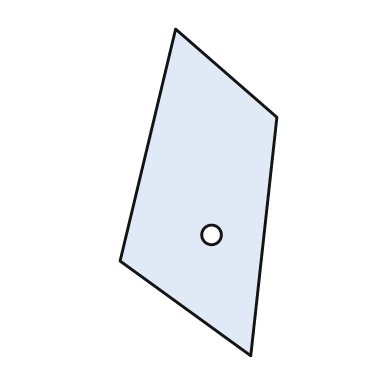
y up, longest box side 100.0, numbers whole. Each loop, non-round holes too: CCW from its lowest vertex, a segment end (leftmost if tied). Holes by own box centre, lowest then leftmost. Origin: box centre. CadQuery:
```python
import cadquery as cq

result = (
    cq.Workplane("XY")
    .moveTo(16.0, -50.0)
    .lineTo(24.0, 23.0)
    .lineTo(-7.0, 50.0)
    .lineTo(-24.0, -21.0)
    .close()
    .moveTo(4.0, -13.0)
    .circle(3.0)
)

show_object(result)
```